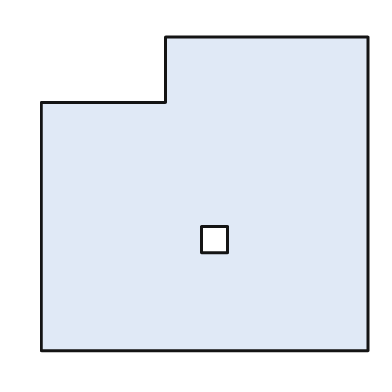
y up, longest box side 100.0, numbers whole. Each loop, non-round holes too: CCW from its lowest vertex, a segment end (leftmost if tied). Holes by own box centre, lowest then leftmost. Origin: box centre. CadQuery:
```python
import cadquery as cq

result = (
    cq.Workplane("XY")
    .moveTo(-50.0, -48.0)
    .lineTo(50.0, -48.0)
    .lineTo(50.0, 48.0)
    .lineTo(-12.0, 48.0)
    .lineTo(-12.0, 28.0)
    .lineTo(-50.0, 28.0)
    .close()
    .moveTo(-1.0, -18.0)
    .lineTo(7.0, -18.0)
    .lineTo(7.0, -10.0)
    .lineTo(-1.0, -10.0)
    .close()
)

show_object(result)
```